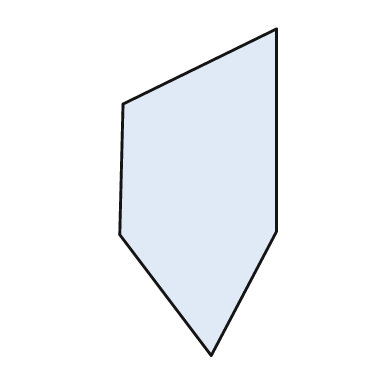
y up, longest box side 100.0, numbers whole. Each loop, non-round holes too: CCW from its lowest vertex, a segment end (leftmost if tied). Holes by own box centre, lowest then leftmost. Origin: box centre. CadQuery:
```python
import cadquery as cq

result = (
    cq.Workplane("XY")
    .moveTo(4.0, -50.0)
    .lineTo(24.0, -12.0)
    .lineTo(24.0, 50.0)
    .lineTo(-23.0, 27.0)
    .lineTo(-24.0, -13.0)
    .close()
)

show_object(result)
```